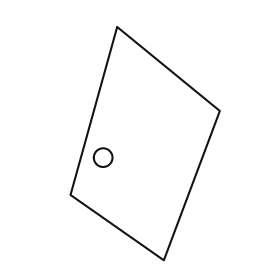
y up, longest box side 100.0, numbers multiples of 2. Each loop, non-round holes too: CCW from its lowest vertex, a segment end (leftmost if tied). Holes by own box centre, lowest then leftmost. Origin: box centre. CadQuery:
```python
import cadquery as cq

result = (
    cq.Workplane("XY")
    .moveTo(8.0, -50.0)
    .lineTo(32.0, 14.0)
    .lineTo(-12.0, 50.0)
    .lineTo(-32.0, -22.0)
    .close()
    .moveTo(-18.0, -6.0)
    .circle(4.0)
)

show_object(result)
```